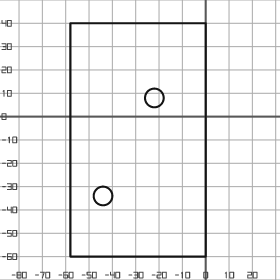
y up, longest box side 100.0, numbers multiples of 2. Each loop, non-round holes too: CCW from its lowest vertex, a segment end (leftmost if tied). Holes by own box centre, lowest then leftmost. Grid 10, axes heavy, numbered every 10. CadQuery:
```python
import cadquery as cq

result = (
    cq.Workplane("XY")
    .moveTo(-58.0, -60.0)
    .lineTo(0.0, -60.0)
    .lineTo(0.0, 40.0)
    .lineTo(-58.0, 40.0)
    .close()
    .moveTo(-44.0, -34.0)
    .circle(4.0)
    .moveTo(-22.0, 8.0)
    .circle(4.0)
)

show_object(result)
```